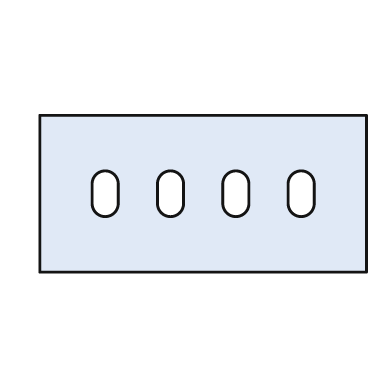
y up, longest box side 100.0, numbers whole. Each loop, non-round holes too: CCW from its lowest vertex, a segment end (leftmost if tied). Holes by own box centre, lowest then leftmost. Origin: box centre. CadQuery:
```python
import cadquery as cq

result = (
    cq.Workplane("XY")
    .moveTo(-50.0, -24.0)
    .lineTo(50.0, -24.0)
    .lineTo(50.0, 24.0)
    .lineTo(-50.0, 24.0)
    .close()
    .moveTo(-34.0, -3.0)
    .threePointArc((-30.0, -7.0), (-26.0, -3.0))
    .lineTo(-26.0, 3.0)
    .threePointArc((-30.0, 7.0), (-34.0, 3.0))
    .close()
    .moveTo(-14.0, -3.0)
    .threePointArc((-10.0, -7.0), (-6.0, -3.0))
    .lineTo(-6.0, 3.0)
    .threePointArc((-10.0, 7.0), (-14.0, 3.0))
    .close()
    .moveTo(6.0, -3.0)
    .threePointArc((10.0, -7.0), (14.0, -3.0))
    .lineTo(14.0, 3.0)
    .threePointArc((10.0, 7.0), (6.0, 3.0))
    .close()
    .moveTo(26.0, -3.0)
    .threePointArc((30.0, -7.0), (34.0, -3.0))
    .lineTo(34.0, 3.0)
    .threePointArc((30.0, 7.0), (26.0, 3.0))
    .close()
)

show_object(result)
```